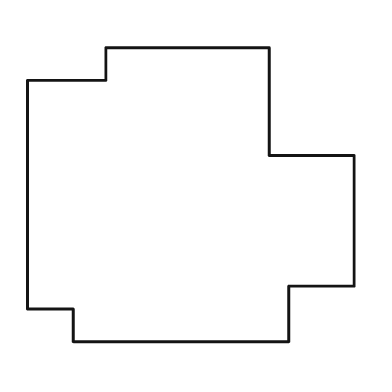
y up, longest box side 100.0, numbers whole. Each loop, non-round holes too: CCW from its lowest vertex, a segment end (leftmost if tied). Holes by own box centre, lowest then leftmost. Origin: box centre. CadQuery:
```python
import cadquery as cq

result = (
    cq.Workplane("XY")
    .moveTo(-36.0, -45.0)
    .lineTo(30.0, -45.0)
    .lineTo(30.0, -28.0)
    .lineTo(50.0, -28.0)
    .lineTo(50.0, 12.0)
    .lineTo(24.0, 12.0)
    .lineTo(24.0, 45.0)
    .lineTo(-26.0, 45.0)
    .lineTo(-26.0, 35.0)
    .lineTo(-50.0, 35.0)
    .lineTo(-50.0, -35.0)
    .lineTo(-36.0, -35.0)
    .close()
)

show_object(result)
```